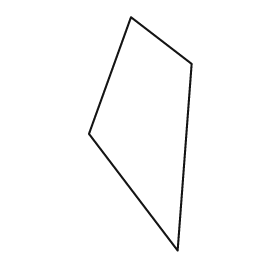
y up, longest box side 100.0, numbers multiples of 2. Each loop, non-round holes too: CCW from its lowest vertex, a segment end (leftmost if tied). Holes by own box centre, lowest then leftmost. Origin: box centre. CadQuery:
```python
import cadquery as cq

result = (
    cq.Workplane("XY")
    .moveTo(16.0, -50.0)
    .lineTo(22.0, 30.0)
    .lineTo(-4.0, 50.0)
    .lineTo(-22.0, 0.0)
    .close()
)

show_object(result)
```